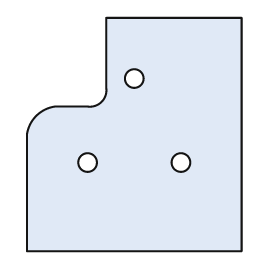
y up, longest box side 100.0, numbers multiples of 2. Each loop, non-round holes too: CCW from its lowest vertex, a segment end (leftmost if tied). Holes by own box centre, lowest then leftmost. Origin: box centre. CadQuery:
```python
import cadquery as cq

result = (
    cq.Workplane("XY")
    .moveTo(-46.0, -50.0)
    .lineTo(46.0, -50.0)
    .lineTo(46.0, 50.0)
    .lineTo(-12.0, 50.0)
    .lineTo(-12.0, 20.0)
    .threePointArc((-14.0, 14.0), (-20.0, 12.0))
    .lineTo(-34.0, 12.0)
    .threePointArc((-42.0, 8.0), (-46.0, 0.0))
    .close()
    .moveTo(-20.0, -12.0)
    .circle(4.0)
    .moveTo(20.0, -12.0)
    .circle(4.0)
    .moveTo(0.0, 24.0)
    .circle(4.0)
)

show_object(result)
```